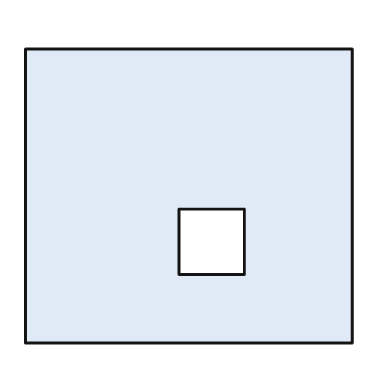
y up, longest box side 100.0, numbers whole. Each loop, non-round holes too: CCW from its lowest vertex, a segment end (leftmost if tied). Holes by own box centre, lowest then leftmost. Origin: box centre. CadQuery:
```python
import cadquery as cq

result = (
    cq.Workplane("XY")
    .moveTo(-50.0, -45.0)
    .lineTo(50.0, -45.0)
    .lineTo(50.0, 45.0)
    .lineTo(-50.0, 45.0)
    .close()
    .moveTo(-3.0, -24.0)
    .lineTo(17.0, -24.0)
    .lineTo(17.0, -4.0)
    .lineTo(-3.0, -4.0)
    .close()
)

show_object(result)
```